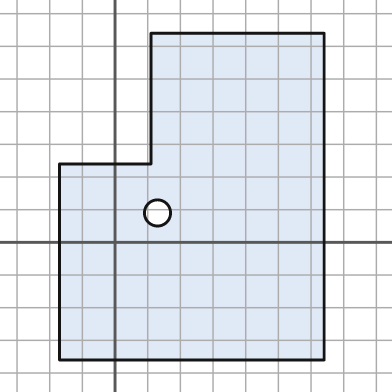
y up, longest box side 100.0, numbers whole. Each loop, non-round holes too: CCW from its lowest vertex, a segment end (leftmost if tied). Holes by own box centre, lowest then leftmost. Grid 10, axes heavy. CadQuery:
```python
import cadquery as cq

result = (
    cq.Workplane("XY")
    .moveTo(-17.0, -36.0)
    .lineTo(64.0, -36.0)
    .lineTo(64.0, 64.0)
    .lineTo(11.0, 64.0)
    .lineTo(11.0, 24.0)
    .lineTo(-17.0, 24.0)
    .close()
    .moveTo(13.0, 9.0)
    .circle(4.0)
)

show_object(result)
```